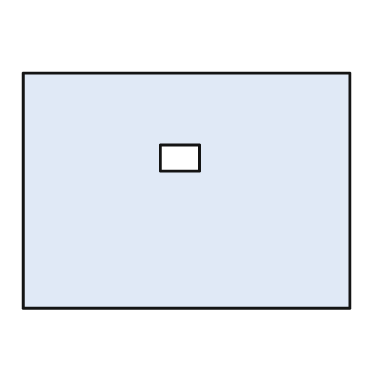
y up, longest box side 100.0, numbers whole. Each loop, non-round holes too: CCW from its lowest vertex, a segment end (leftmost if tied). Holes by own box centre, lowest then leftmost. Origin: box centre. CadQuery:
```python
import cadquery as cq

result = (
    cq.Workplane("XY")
    .moveTo(-50.0, -36.0)
    .lineTo(50.0, -36.0)
    .lineTo(50.0, 36.0)
    .lineTo(-50.0, 36.0)
    .close()
    .moveTo(-8.0, 6.0)
    .lineTo(4.0, 6.0)
    .lineTo(4.0, 14.0)
    .lineTo(-8.0, 14.0)
    .close()
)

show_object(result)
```